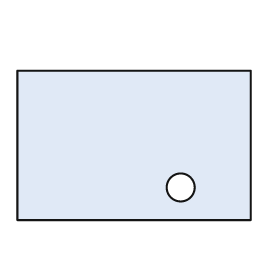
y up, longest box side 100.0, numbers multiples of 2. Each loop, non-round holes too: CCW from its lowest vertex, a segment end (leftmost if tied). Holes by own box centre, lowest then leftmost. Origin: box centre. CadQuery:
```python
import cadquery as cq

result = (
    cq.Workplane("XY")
    .moveTo(-50.0, -32.0)
    .lineTo(50.0, -32.0)
    .lineTo(50.0, 32.0)
    .lineTo(-50.0, 32.0)
    .close()
    .moveTo(20.0, -18.0)
    .circle(6.0)
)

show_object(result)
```